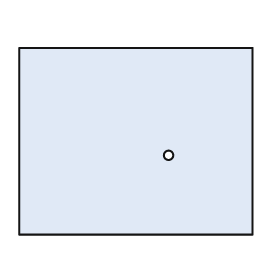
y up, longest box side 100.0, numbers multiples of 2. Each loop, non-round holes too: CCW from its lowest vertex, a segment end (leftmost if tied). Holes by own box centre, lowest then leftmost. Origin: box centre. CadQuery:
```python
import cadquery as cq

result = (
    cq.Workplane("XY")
    .moveTo(-50.0, -40.0)
    .lineTo(50.0, -40.0)
    .lineTo(50.0, 40.0)
    .lineTo(-50.0, 40.0)
    .close()
    .moveTo(14.0, -6.0)
    .circle(2.0)
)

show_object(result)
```